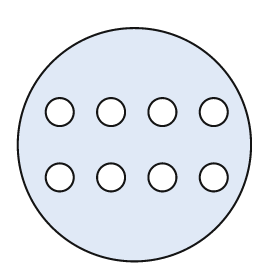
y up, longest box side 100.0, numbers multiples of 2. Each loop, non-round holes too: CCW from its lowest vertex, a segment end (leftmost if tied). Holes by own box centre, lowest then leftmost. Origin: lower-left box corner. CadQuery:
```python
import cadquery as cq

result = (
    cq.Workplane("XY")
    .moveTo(50.0, 50.0)
    .circle(50.0)
    .moveTo(18.0, 36.0)
    .circle(6.0)
    .moveTo(40.0, 36.0)
    .circle(6.0)
    .moveTo(62.0, 36.0)
    .circle(6.0)
    .moveTo(84.0, 36.0)
    .circle(6.0)
    .moveTo(18.0, 64.0)
    .circle(6.0)
    .moveTo(40.0, 64.0)
    .circle(6.0)
    .moveTo(62.0, 64.0)
    .circle(6.0)
    .moveTo(84.0, 64.0)
    .circle(6.0)
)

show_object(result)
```